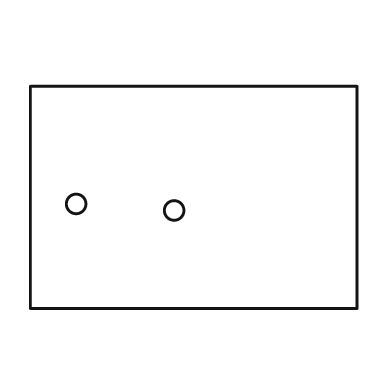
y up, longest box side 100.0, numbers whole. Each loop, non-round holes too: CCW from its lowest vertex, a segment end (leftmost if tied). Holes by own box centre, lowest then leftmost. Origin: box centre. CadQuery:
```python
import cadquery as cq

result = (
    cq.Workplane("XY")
    .moveTo(-50.0, -34.0)
    .lineTo(50.0, -34.0)
    .lineTo(50.0, 34.0)
    .lineTo(-50.0, 34.0)
    .close()
    .moveTo(-6.0, -4.0)
    .circle(3.0)
    .moveTo(-36.0, -2.0)
    .circle(3.0)
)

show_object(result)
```